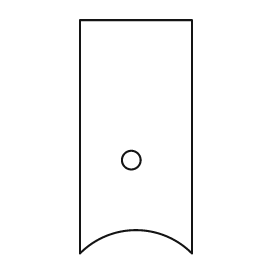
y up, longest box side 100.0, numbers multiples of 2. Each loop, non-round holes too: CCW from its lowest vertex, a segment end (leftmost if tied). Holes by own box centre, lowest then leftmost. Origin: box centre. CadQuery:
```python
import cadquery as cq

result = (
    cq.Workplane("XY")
    .moveTo(-24.0, -50.0)
    .threePointArc((0.0, -40.0), (24.0, -50.0))
    .lineTo(24.0, 50.0)
    .lineTo(-24.0, 50.0)
    .close()
    .moveTo(-2.0, -10.0)
    .circle(4.0)
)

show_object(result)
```